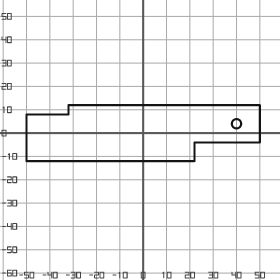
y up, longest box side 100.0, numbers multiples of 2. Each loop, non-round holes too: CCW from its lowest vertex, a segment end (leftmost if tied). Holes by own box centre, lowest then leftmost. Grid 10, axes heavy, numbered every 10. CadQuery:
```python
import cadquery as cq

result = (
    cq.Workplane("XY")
    .moveTo(-50.0, -12.0)
    .lineTo(22.0, -12.0)
    .lineTo(22.0, -4.0)
    .lineTo(50.0, -4.0)
    .lineTo(50.0, 12.0)
    .lineTo(-32.0, 12.0)
    .lineTo(-32.0, 8.0)
    .lineTo(-50.0, 8.0)
    .close()
    .moveTo(40.0, 4.0)
    .circle(2.0)
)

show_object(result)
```